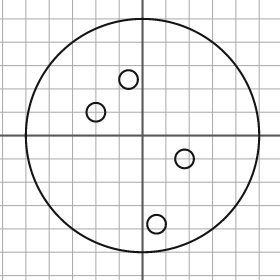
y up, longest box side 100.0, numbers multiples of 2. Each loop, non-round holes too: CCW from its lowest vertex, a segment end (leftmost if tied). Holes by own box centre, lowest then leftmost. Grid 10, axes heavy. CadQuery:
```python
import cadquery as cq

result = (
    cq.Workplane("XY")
    .moveTo(0.0, 0.0)
    .circle(50.0)
    .moveTo(6.0, -38.0)
    .circle(4.0)
    .moveTo(18.0, -10.0)
    .circle(4.0)
    .moveTo(-20.0, 10.0)
    .circle(4.0)
    .moveTo(-6.0, 24.0)
    .circle(4.0)
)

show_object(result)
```